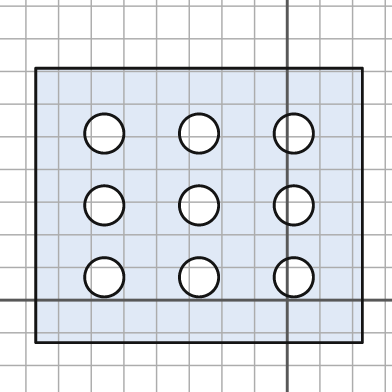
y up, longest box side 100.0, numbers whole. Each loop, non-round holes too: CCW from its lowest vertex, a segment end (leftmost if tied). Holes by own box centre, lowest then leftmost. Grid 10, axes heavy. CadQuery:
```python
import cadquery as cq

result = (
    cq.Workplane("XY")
    .moveTo(-77.0, -13.0)
    .lineTo(23.0, -13.0)
    .lineTo(23.0, 71.0)
    .lineTo(-77.0, 71.0)
    .close()
    .moveTo(-56.0, 7.0)
    .circle(6.0)
    .moveTo(-27.0, 7.0)
    .circle(6.0)
    .moveTo(2.0, 7.0)
    .circle(6.0)
    .moveTo(-56.0, 29.0)
    .circle(6.0)
    .moveTo(-27.0, 29.0)
    .circle(6.0)
    .moveTo(2.0, 29.0)
    .circle(6.0)
    .moveTo(-56.0, 51.0)
    .circle(6.0)
    .moveTo(-27.0, 51.0)
    .circle(6.0)
    .moveTo(2.0, 51.0)
    .circle(6.0)
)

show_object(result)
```